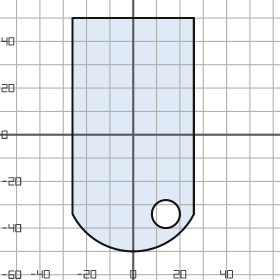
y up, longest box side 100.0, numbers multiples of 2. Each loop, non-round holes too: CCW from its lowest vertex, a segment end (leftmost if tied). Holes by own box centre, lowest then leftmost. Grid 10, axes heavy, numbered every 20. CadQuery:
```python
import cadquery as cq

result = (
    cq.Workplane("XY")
    .moveTo(-26.0, -34.0)
    .threePointArc((0.0, -50.0), (26.0, -34.0))
    .lineTo(26.0, 50.0)
    .lineTo(-26.0, 50.0)
    .close()
    .moveTo(14.0, -34.0)
    .circle(6.0)
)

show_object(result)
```